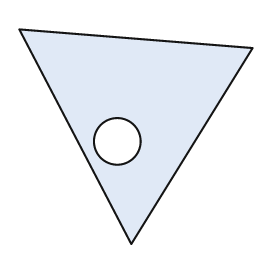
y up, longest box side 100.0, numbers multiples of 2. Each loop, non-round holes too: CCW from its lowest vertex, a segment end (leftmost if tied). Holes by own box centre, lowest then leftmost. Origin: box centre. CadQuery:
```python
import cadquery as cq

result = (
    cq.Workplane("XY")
    .moveTo(-2.0, -46.0)
    .lineTo(50.0, 38.0)
    .lineTo(-50.0, 46.0)
    .close()
    .moveTo(-8.0, -2.0)
    .circle(10.0)
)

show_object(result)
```